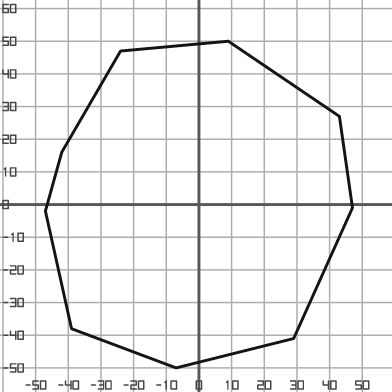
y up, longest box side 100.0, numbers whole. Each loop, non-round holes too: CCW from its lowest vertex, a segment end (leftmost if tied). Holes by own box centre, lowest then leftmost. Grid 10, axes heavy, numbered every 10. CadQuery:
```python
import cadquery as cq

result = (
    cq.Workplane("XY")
    .moveTo(-7.0, -50.0)
    .lineTo(29.0, -41.0)
    .lineTo(47.0, -1.0)
    .lineTo(43.0, 27.0)
    .lineTo(9.0, 50.0)
    .lineTo(-24.0, 47.0)
    .lineTo(-42.0, 16.0)
    .lineTo(-47.0, -2.0)
    .lineTo(-39.0, -38.0)
    .close()
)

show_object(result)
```